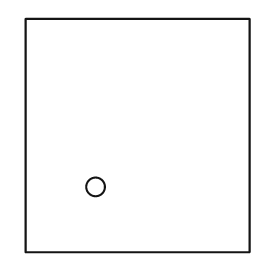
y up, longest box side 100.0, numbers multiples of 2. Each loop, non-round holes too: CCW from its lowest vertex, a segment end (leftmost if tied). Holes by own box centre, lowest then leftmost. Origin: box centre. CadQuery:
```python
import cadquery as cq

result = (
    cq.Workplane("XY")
    .moveTo(-48.0, -50.0)
    .lineTo(48.0, -50.0)
    .lineTo(48.0, 50.0)
    .lineTo(-48.0, 50.0)
    .close()
    .moveTo(-18.0, -22.0)
    .circle(4.0)
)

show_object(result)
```